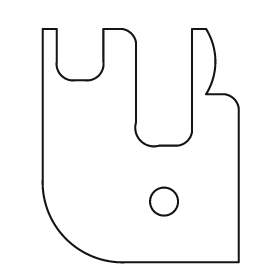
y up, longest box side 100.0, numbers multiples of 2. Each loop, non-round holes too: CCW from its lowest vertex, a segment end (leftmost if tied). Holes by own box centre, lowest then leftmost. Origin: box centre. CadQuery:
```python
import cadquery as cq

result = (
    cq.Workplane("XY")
    .moveTo(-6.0, -50.0)
    .lineTo(42.0, -50.0)
    .lineTo(42.0, 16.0)
    .threePointArc((40.0, 20.0), (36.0, 22.0))
    .lineTo(28.0, 22.0)
    .threePointArc((32.0, 36.0), (28.0, 50.0))
    .lineTo(22.0, 50.0)
    .lineTo(22.0, 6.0)
    .threePointArc((20.0, 2.0), (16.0, 0.0))
    .lineTo(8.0, 0.0)
    .threePointArc((0.0, 2.0), (-2.0, 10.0))
    .lineTo(-2.0, 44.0)
    .threePointArc((-4.0, 48.0), (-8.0, 50.0))
    .lineTo(-16.0, 50.0)
    .lineTo(-16.0, 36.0)
    .threePointArc((-18.0, 30.0), (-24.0, 28.0))
    .lineTo(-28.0, 28.0)
    .threePointArc((-34.0, 30.0), (-36.0, 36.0))
    .lineTo(-36.0, 50.0)
    .lineTo(-42.0, 50.0)
    .lineTo(-42.0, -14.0)
    .threePointArc((-32.0, -40.0), (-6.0, -50.0))
    .close()
    .moveTo(10.0, -24.0)
    .circle(6.0)
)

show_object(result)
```